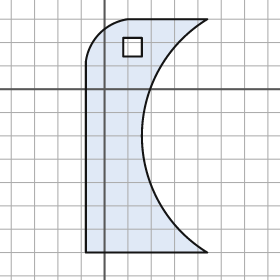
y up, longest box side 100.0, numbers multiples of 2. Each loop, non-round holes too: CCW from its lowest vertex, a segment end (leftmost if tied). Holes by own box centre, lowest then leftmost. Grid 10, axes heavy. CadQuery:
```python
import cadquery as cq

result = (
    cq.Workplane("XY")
    .moveTo(-8.0, -70.0)
    .lineTo(44.0, -70.0)
    .threePointArc((16.0, -20.0), (44.0, 30.0))
    .lineTo(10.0, 30.0)
    .threePointArc((-2.0, 24.0), (-8.0, 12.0))
    .close()
    .moveTo(8.0, 14.0)
    .lineTo(16.0, 14.0)
    .lineTo(16.0, 22.0)
    .lineTo(8.0, 22.0)
    .close()
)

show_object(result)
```